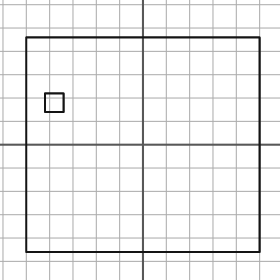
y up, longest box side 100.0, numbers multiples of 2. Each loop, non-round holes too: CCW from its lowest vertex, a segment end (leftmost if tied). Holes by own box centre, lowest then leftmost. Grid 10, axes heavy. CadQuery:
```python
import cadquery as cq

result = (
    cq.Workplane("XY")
    .moveTo(-50.0, -46.0)
    .lineTo(50.0, -46.0)
    .lineTo(50.0, 46.0)
    .lineTo(-50.0, 46.0)
    .close()
    .moveTo(-42.0, 14.0)
    .lineTo(-34.0, 14.0)
    .lineTo(-34.0, 22.0)
    .lineTo(-42.0, 22.0)
    .close()
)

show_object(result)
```